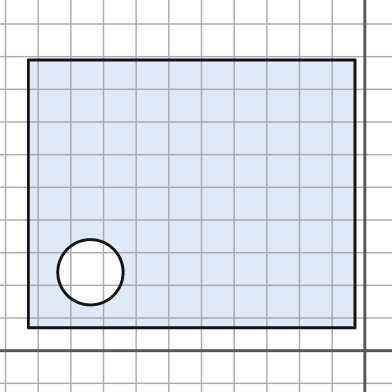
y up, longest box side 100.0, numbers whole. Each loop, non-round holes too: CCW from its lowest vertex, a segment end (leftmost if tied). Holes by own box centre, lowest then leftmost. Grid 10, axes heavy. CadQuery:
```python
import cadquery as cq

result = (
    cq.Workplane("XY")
    .moveTo(-103.0, 7.0)
    .lineTo(-3.0, 7.0)
    .lineTo(-3.0, 89.0)
    .lineTo(-103.0, 89.0)
    .close()
    .moveTo(-84.0, 24.0)
    .circle(10.0)
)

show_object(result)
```